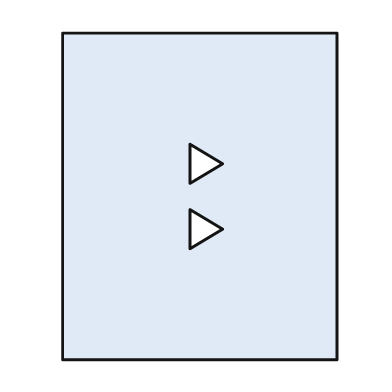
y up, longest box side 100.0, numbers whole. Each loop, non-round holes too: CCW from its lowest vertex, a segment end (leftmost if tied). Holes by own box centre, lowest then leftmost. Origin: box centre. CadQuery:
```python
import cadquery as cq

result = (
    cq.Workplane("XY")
    .moveTo(-42.0, -50.0)
    .lineTo(42.0, -50.0)
    .lineTo(42.0, 50.0)
    .lineTo(-42.0, 50.0)
    .close()
    .moveTo(-3.0, -16.0)
    .lineTo(7.0, -10.0)
    .lineTo(-3.0, -4.0)
    .close()
    .moveTo(-3.0, 4.0)
    .lineTo(7.0, 10.0)
    .lineTo(-3.0, 16.0)
    .close()
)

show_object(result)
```